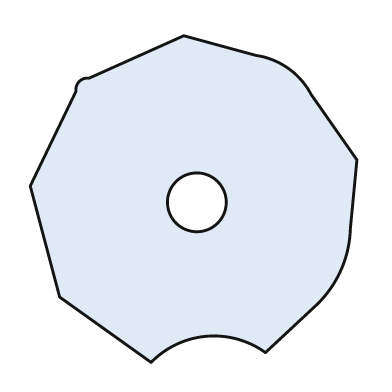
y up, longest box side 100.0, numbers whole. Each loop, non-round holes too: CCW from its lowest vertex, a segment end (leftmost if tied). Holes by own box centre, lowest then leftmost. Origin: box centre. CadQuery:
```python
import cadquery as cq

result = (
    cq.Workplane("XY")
    .moveTo(-13.0, -50.0)
    .threePointArc((4.0, -42.0), (22.0, -47.0))
    .lineTo(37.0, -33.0)
    .threePointArc((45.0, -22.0), (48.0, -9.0))
    .lineTo(50.0, 12.0)
    .lineTo(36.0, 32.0)
    .threePointArc((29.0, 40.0), (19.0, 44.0))
    .lineTo(-3.0, 50.0)
    .lineTo(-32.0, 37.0)
    .threePointArc((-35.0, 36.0), (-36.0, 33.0))
    .lineTo(-50.0, 4.0)
    .lineTo(-41.0, -30.0)
    .close()
    .moveTo(1.0, -1.0)
    .circle(9.0)
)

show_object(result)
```